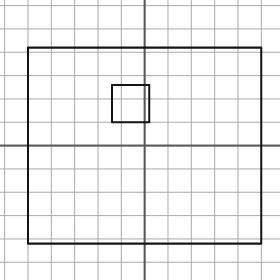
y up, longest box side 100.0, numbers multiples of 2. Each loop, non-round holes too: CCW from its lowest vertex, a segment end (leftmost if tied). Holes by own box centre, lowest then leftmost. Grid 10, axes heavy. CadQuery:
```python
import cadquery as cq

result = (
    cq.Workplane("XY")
    .moveTo(-50.0, -42.0)
    .lineTo(50.0, -42.0)
    .lineTo(50.0, 42.0)
    .lineTo(-50.0, 42.0)
    .close()
    .moveTo(-14.0, 10.0)
    .lineTo(2.0, 10.0)
    .lineTo(2.0, 26.0)
    .lineTo(-14.0, 26.0)
    .close()
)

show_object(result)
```